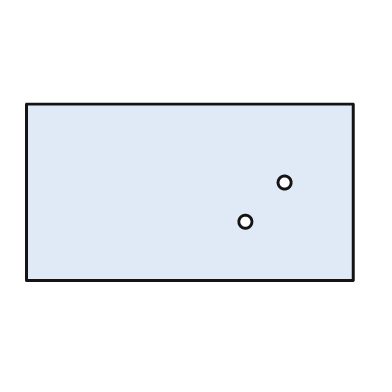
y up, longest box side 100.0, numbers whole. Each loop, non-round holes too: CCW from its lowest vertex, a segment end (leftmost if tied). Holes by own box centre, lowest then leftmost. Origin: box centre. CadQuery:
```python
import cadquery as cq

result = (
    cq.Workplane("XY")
    .moveTo(-50.0, -27.0)
    .lineTo(50.0, -27.0)
    .lineTo(50.0, 27.0)
    .lineTo(-50.0, 27.0)
    .close()
    .moveTo(17.0, -9.0)
    .circle(2.0)
    .moveTo(29.0, 3.0)
    .circle(2.0)
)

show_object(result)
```